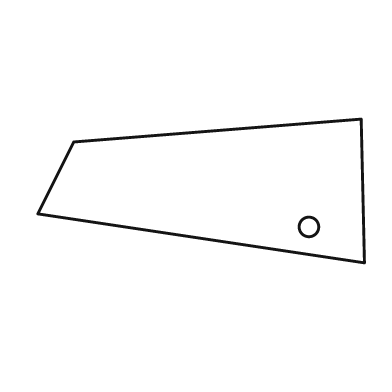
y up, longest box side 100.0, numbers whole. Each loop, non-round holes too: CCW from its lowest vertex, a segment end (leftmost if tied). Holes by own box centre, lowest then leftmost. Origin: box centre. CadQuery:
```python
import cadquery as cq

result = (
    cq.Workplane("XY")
    .moveTo(50.0, -22.0)
    .lineTo(49.0, 22.0)
    .lineTo(-39.0, 15.0)
    .lineTo(-50.0, -7.0)
    .close()
    .moveTo(33.0, -11.0)
    .circle(3.0)
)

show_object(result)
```